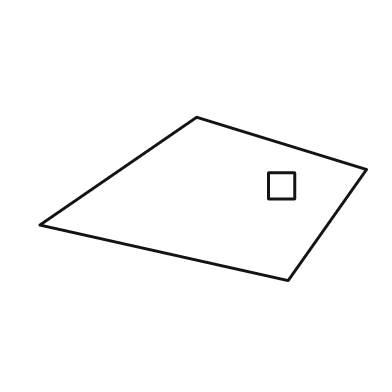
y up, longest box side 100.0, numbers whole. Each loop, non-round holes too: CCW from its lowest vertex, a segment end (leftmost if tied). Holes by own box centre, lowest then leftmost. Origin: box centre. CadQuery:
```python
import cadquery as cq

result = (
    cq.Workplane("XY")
    .moveTo(26.0, -25.0)
    .lineTo(50.0, 9.0)
    .lineTo(-2.0, 25.0)
    .lineTo(-50.0, -8.0)
    .close()
    .moveTo(20.0, 0.0)
    .lineTo(28.0, 0.0)
    .lineTo(28.0, 8.0)
    .lineTo(20.0, 8.0)
    .close()
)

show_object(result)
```